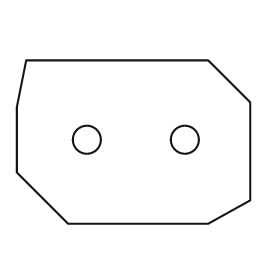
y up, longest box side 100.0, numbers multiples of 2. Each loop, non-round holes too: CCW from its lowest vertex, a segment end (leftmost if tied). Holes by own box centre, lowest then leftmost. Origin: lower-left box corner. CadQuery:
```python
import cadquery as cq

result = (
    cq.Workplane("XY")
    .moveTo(22.0, 0.0)
    .lineTo(82.0, 0.0)
    .lineTo(100.0, 10.0)
    .lineTo(100.0, 52.0)
    .lineTo(82.0, 70.0)
    .lineTo(4.0, 70.0)
    .lineTo(0.0, 50.0)
    .lineTo(0.0, 22.0)
    .close()
    .moveTo(30.0, 36.0)
    .circle(6.0)
    .moveTo(72.0, 36.0)
    .circle(6.0)
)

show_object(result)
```